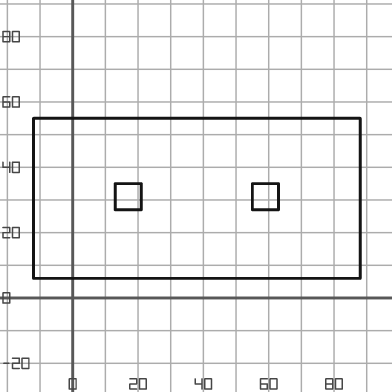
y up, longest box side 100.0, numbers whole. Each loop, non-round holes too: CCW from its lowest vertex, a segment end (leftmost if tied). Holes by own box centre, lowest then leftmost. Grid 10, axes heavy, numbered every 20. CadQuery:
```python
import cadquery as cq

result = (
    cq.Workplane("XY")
    .moveTo(-12.0, 6.0)
    .lineTo(88.0, 6.0)
    .lineTo(88.0, 55.0)
    .lineTo(-12.0, 55.0)
    .close()
    .moveTo(13.0, 27.0)
    .lineTo(21.0, 27.0)
    .lineTo(21.0, 35.0)
    .lineTo(13.0, 35.0)
    .close()
    .moveTo(55.0, 27.0)
    .lineTo(63.0, 27.0)
    .lineTo(63.0, 35.0)
    .lineTo(55.0, 35.0)
    .close()
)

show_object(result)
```